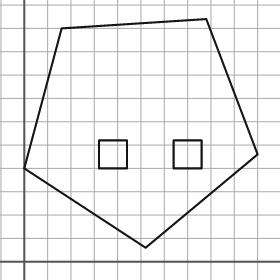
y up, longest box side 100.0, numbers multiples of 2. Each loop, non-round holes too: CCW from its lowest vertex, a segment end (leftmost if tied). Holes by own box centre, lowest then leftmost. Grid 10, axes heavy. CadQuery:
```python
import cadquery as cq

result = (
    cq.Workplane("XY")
    .moveTo(52.0, 6.0)
    .lineTo(100.0, 46.0)
    .lineTo(78.0, 104.0)
    .lineTo(16.0, 100.0)
    .lineTo(0.0, 40.0)
    .close()
    .moveTo(32.0, 40.0)
    .lineTo(44.0, 40.0)
    .lineTo(44.0, 52.0)
    .lineTo(32.0, 52.0)
    .close()
    .moveTo(64.0, 40.0)
    .lineTo(76.0, 40.0)
    .lineTo(76.0, 52.0)
    .lineTo(64.0, 52.0)
    .close()
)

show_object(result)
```